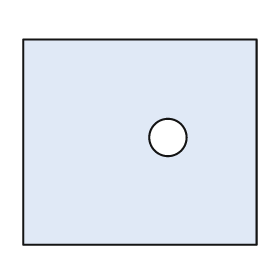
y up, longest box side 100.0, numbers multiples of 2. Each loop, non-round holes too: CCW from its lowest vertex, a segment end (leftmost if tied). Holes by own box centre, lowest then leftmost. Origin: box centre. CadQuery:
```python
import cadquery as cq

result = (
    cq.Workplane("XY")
    .moveTo(-50.0, -44.0)
    .lineTo(50.0, -44.0)
    .lineTo(50.0, 44.0)
    .lineTo(-50.0, 44.0)
    .close()
    .moveTo(12.0, 2.0)
    .circle(8.0)
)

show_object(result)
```